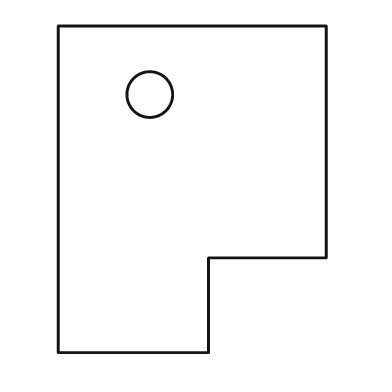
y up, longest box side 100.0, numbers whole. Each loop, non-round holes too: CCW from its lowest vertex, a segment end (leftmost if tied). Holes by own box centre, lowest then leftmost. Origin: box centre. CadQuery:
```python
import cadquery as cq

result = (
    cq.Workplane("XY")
    .moveTo(-41.0, -50.0)
    .lineTo(5.0, -50.0)
    .lineTo(5.0, -21.0)
    .lineTo(41.0, -21.0)
    .lineTo(41.0, 50.0)
    .lineTo(-41.0, 50.0)
    .close()
    .moveTo(-13.0, 29.0)
    .circle(7.0)
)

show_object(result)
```